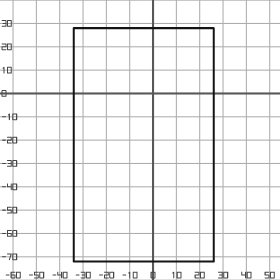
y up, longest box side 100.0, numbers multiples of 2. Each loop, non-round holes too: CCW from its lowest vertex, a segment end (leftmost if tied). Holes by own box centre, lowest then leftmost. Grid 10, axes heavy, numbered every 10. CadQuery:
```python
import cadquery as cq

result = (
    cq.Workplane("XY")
    .moveTo(-34.0, -72.0)
    .lineTo(26.0, -72.0)
    .lineTo(26.0, 28.0)
    .lineTo(-34.0, 28.0)
    .close()
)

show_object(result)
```